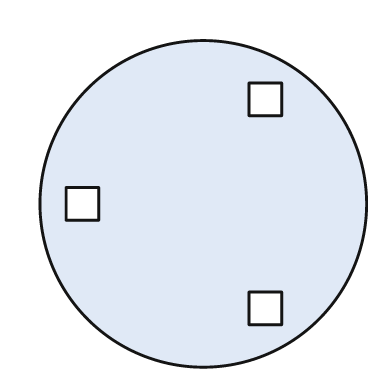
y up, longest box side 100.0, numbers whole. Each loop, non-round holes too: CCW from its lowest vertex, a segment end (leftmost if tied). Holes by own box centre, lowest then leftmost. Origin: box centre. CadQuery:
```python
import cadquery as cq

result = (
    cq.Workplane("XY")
    .moveTo(0.0, 0.0)
    .circle(50.0)
    .moveTo(14.0, -37.0)
    .lineTo(24.0, -37.0)
    .lineTo(24.0, -27.0)
    .lineTo(14.0, -27.0)
    .close()
    .moveTo(-42.0, -5.0)
    .lineTo(-32.0, -5.0)
    .lineTo(-32.0, 5.0)
    .lineTo(-42.0, 5.0)
    .close()
    .moveTo(14.0, 27.0)
    .lineTo(24.0, 27.0)
    .lineTo(24.0, 37.0)
    .lineTo(14.0, 37.0)
    .close()
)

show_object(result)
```